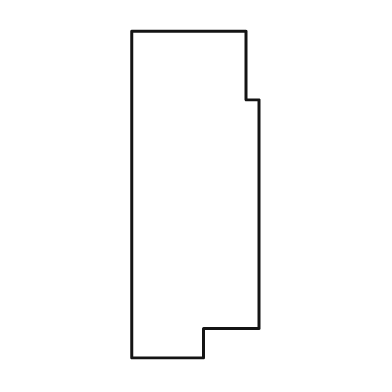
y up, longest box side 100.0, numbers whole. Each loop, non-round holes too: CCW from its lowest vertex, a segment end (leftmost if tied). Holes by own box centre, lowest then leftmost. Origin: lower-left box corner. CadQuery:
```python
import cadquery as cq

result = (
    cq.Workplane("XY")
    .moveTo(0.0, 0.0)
    .lineTo(22.0, 0.0)
    .lineTo(22.0, 9.0)
    .lineTo(39.0, 9.0)
    .lineTo(39.0, 79.0)
    .lineTo(35.0, 79.0)
    .lineTo(35.0, 100.0)
    .lineTo(0.0, 100.0)
    .close()
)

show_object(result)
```